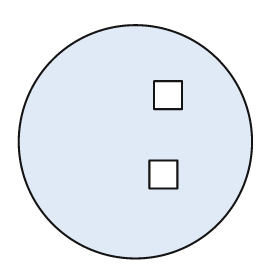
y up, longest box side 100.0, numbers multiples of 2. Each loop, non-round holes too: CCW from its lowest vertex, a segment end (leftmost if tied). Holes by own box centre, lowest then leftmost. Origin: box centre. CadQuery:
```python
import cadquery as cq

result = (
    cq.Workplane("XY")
    .moveTo(0.0, 0.0)
    .circle(50.0)
    .moveTo(6.0, -20.0)
    .lineTo(18.0, -20.0)
    .lineTo(18.0, -8.0)
    .lineTo(6.0, -8.0)
    .close()
    .moveTo(8.0, 14.0)
    .lineTo(20.0, 14.0)
    .lineTo(20.0, 26.0)
    .lineTo(8.0, 26.0)
    .close()
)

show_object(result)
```